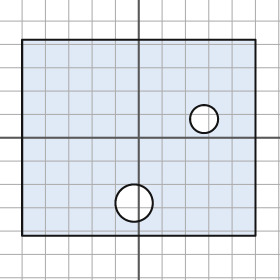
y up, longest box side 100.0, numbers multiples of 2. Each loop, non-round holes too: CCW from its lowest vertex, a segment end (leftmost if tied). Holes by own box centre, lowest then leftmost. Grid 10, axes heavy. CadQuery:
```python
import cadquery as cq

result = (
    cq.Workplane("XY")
    .moveTo(-50.0, -42.0)
    .lineTo(50.0, -42.0)
    .lineTo(50.0, 42.0)
    .lineTo(-50.0, 42.0)
    .close()
    .moveTo(-2.0, -28.0)
    .circle(8.0)
    .moveTo(28.0, 8.0)
    .circle(6.0)
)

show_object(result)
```